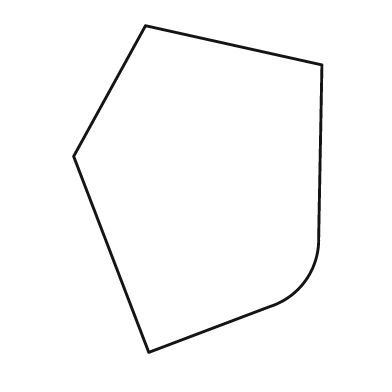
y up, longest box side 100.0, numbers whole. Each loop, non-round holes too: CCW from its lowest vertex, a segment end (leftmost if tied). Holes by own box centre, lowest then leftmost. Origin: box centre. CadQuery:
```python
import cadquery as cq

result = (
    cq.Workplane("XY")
    .moveTo(-15.0, -50.0)
    .lineTo(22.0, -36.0)
    .threePointArc((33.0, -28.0), (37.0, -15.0))
    .lineTo(38.0, 38.0)
    .lineTo(-16.0, 50.0)
    .lineTo(-38.0, 10.0)
    .close()
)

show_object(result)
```